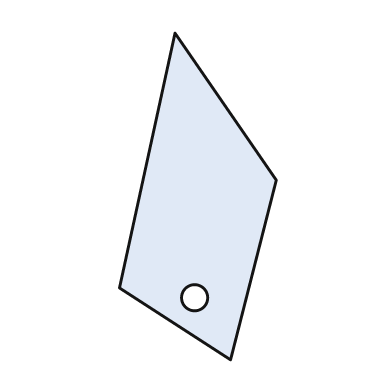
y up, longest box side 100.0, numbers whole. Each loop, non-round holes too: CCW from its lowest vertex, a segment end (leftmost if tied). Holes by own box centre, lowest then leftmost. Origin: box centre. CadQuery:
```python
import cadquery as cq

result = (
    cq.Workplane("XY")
    .moveTo(10.0, -50.0)
    .lineTo(24.0, 5.0)
    .lineTo(-7.0, 50.0)
    .lineTo(-24.0, -28.0)
    .close()
    .moveTo(-1.0, -31.0)
    .circle(4.0)
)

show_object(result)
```